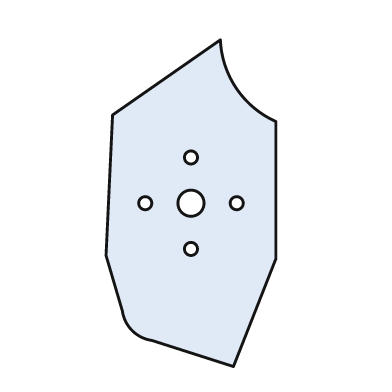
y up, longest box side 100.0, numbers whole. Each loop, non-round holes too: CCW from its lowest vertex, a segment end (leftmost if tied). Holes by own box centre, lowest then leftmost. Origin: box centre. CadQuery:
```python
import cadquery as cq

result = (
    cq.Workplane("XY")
    .moveTo(13.0, -50.0)
    .lineTo(26.0, -17.0)
    .lineTo(26.0, 25.0)
    .threePointArc((14.0, 35.0), (9.0, 50.0))
    .lineTo(-24.0, 27.0)
    .lineTo(-26.0, -16.0)
    .lineTo(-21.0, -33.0)
    .threePointArc((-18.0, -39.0), (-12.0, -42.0))
    .close()
    .moveTo(0.0, -14.0)
    .circle(2.0)
    .moveTo(-14.0, 0.0)
    .circle(2.0)
    .moveTo(0.0, 0.0)
    .circle(4.0)
    .moveTo(14.0, 0.0)
    .circle(2.0)
    .moveTo(0.0, 14.0)
    .circle(2.0)
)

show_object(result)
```